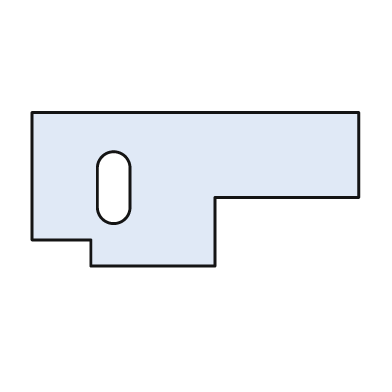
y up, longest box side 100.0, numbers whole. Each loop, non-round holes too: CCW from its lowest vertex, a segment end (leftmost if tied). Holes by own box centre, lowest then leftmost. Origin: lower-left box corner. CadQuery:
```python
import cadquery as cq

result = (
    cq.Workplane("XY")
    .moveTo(18.0, 0.0)
    .lineTo(56.0, 0.0)
    .lineTo(56.0, 21.0)
    .lineTo(100.0, 21.0)
    .lineTo(100.0, 47.0)
    .lineTo(0.0, 47.0)
    .lineTo(0.0, 8.0)
    .lineTo(18.0, 8.0)
    .close()
    .moveTo(20.0, 18.0)
    .threePointArc((25.0, 13.0), (30.0, 18.0))
    .lineTo(30.0, 30.0)
    .threePointArc((25.0, 35.0), (20.0, 30.0))
    .close()
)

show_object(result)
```